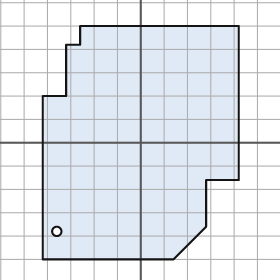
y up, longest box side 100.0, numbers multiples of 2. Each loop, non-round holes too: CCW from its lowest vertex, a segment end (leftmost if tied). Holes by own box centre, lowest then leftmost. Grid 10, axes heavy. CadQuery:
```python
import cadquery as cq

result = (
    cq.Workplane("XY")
    .moveTo(-42.0, -50.0)
    .lineTo(14.0, -50.0)
    .lineTo(28.0, -36.0)
    .lineTo(28.0, -16.0)
    .lineTo(42.0, -16.0)
    .lineTo(42.0, 50.0)
    .lineTo(-26.0, 50.0)
    .lineTo(-26.0, 42.0)
    .lineTo(-32.0, 42.0)
    .lineTo(-32.0, 20.0)
    .lineTo(-42.0, 20.0)
    .close()
    .moveTo(-36.0, -38.0)
    .circle(2.0)
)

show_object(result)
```